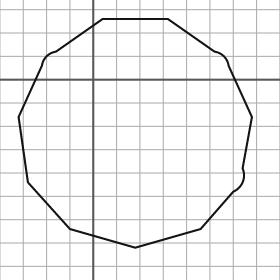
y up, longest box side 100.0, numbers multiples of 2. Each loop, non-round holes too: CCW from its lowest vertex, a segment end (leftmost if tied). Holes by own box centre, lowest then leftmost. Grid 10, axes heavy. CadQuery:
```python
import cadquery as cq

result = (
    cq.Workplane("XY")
    .moveTo(18.0, -72.0)
    .lineTo(46.0, -64.0)
    .lineTo(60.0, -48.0)
    .threePointArc((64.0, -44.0), (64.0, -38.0))
    .lineTo(68.0, -16.0)
    .lineTo(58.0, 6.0)
    .threePointArc((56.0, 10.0), (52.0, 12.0))
    .lineTo(32.0, 26.0)
    .lineTo(4.0, 26.0)
    .lineTo(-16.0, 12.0)
    .threePointArc((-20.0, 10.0), (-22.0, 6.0))
    .lineTo(-32.0, -16.0)
    .lineTo(-28.0, -44.0)
    .lineTo(-10.0, -64.0)
    .close()
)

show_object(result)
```